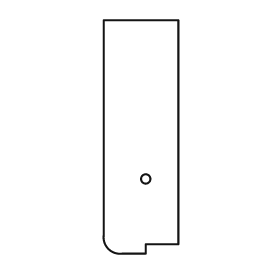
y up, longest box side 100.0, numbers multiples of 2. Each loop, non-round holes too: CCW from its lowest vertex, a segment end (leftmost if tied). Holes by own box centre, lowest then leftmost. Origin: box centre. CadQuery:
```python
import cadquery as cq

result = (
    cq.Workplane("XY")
    .moveTo(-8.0, -50.0)
    .lineTo(2.0, -50.0)
    .lineTo(2.0, -46.0)
    .lineTo(16.0, -46.0)
    .lineTo(16.0, 50.0)
    .lineTo(-16.0, 50.0)
    .lineTo(-16.0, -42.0)
    .threePointArc((-14.0, -48.0), (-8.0, -50.0))
    .close()
    .moveTo(2.0, -18.0)
    .circle(2.0)
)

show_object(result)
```